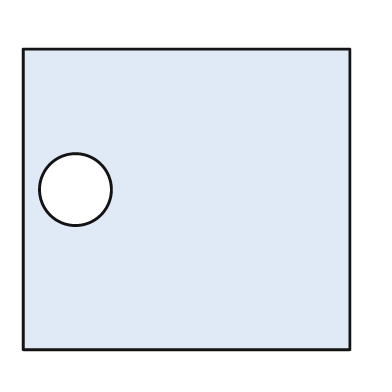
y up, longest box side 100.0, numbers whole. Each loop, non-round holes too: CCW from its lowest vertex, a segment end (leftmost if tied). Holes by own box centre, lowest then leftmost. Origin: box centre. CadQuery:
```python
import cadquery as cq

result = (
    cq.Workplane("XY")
    .moveTo(-50.0, -46.0)
    .lineTo(50.0, -46.0)
    .lineTo(50.0, 46.0)
    .lineTo(-50.0, 46.0)
    .close()
    .moveTo(-34.0, 3.0)
    .circle(11.0)
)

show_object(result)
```